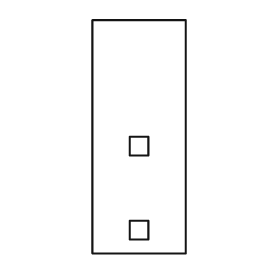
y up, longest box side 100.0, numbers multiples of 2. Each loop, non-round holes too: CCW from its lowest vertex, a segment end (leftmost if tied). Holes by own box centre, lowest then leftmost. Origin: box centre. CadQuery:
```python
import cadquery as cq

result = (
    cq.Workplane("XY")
    .moveTo(-20.0, -50.0)
    .lineTo(20.0, -50.0)
    .lineTo(20.0, 50.0)
    .lineTo(-20.0, 50.0)
    .close()
    .moveTo(-4.0, -44.0)
    .lineTo(4.0, -44.0)
    .lineTo(4.0, -36.0)
    .lineTo(-4.0, -36.0)
    .close()
    .moveTo(-4.0, -8.0)
    .lineTo(4.0, -8.0)
    .lineTo(4.0, 0.0)
    .lineTo(-4.0, 0.0)
    .close()
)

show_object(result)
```